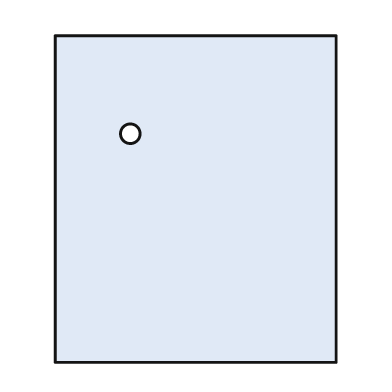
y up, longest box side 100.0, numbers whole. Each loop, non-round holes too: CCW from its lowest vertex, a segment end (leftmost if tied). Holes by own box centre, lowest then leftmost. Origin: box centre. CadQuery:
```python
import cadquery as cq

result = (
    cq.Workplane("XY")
    .moveTo(-43.0, -50.0)
    .lineTo(43.0, -50.0)
    .lineTo(43.0, 50.0)
    .lineTo(-43.0, 50.0)
    .close()
    .moveTo(-20.0, 20.0)
    .circle(3.0)
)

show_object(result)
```